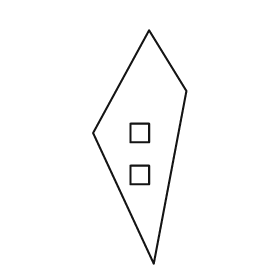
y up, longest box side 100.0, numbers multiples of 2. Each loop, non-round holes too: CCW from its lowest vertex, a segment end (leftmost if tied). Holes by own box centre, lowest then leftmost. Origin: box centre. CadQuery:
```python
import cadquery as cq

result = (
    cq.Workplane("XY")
    .moveTo(6.0, -50.0)
    .lineTo(20.0, 24.0)
    .lineTo(4.0, 50.0)
    .lineTo(-20.0, 6.0)
    .close()
    .moveTo(-4.0, -16.0)
    .lineTo(4.0, -16.0)
    .lineTo(4.0, -8.0)
    .lineTo(-4.0, -8.0)
    .close()
    .moveTo(-4.0, 2.0)
    .lineTo(4.0, 2.0)
    .lineTo(4.0, 10.0)
    .lineTo(-4.0, 10.0)
    .close()
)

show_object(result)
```